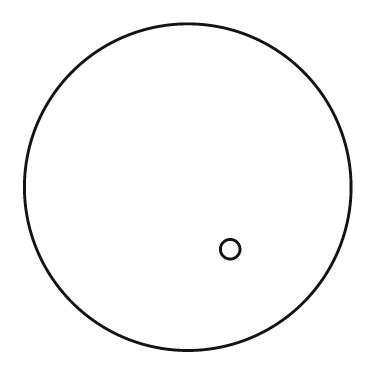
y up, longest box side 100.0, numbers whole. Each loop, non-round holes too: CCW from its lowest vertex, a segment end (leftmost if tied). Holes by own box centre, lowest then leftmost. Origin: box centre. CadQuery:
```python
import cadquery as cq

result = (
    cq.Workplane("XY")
    .moveTo(0.0, 0.0)
    .circle(50.0)
    .moveTo(13.0, -19.0)
    .circle(3.0)
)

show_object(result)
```